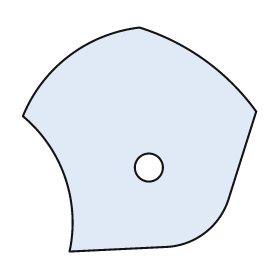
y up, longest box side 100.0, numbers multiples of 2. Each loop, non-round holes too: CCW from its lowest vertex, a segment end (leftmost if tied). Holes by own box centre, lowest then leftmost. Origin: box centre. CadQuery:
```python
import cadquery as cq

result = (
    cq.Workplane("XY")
    .moveTo(-30.0, -48.0)
    .lineTo(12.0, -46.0)
    .threePointArc((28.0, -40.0), (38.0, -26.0))
    .lineTo(50.0, 12.0)
    .threePointArc((28.0, 34.0), (0.0, 48.0))
    .threePointArc((-30.0, 36.0), (-50.0, 10.0))
    .threePointArc((-32.0, -16.0), (-30.0, -48.0))
    .close()
    .moveTo(4.0, -12.0)
    .circle(6.0)
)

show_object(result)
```